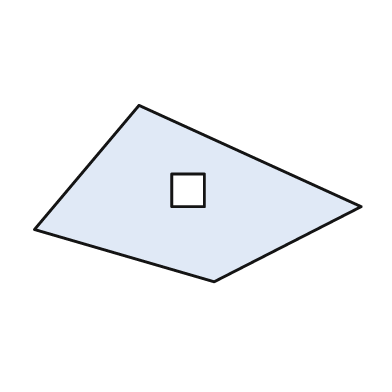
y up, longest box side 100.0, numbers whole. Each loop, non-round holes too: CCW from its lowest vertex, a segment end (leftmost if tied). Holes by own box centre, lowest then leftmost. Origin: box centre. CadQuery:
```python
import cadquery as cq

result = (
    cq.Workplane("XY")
    .moveTo(5.0, -27.0)
    .lineTo(50.0, -4.0)
    .lineTo(-18.0, 27.0)
    .lineTo(-50.0, -11.0)
    .close()
    .moveTo(-8.0, -4.0)
    .lineTo(2.0, -4.0)
    .lineTo(2.0, 6.0)
    .lineTo(-8.0, 6.0)
    .close()
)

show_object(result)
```